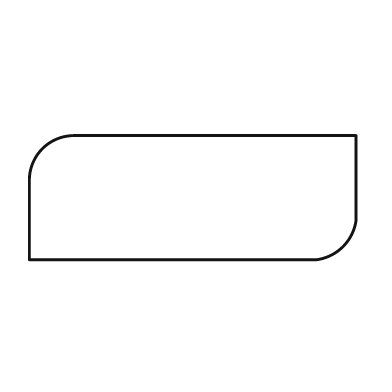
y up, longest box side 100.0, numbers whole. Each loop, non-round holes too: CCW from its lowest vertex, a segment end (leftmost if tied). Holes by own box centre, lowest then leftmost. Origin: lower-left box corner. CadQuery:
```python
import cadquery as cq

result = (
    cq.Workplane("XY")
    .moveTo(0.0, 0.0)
    .lineTo(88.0, 0.0)
    .threePointArc((96.0, 4.0), (100.0, 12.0))
    .lineTo(100.0, 38.0)
    .lineTo(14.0, 38.0)
    .threePointArc((4.0, 34.0), (0.0, 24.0))
    .close()
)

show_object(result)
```